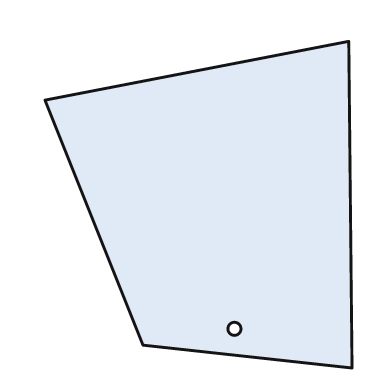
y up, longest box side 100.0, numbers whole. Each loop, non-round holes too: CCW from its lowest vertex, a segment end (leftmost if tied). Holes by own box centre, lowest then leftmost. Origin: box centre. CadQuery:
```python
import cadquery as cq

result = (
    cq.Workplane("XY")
    .moveTo(47.0, -50.0)
    .lineTo(46.0, 50.0)
    .lineTo(-47.0, 32.0)
    .lineTo(-17.0, -43.0)
    .close()
    .moveTo(11.0, -38.0)
    .circle(2.0)
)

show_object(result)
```